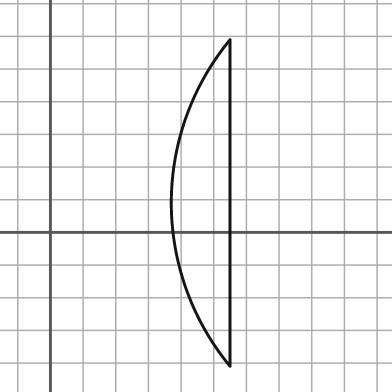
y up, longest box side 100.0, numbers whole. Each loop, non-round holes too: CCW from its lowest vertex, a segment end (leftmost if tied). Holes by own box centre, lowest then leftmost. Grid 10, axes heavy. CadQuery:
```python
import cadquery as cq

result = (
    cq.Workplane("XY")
    .moveTo(55.0, -41.0)
    .lineTo(55.0, 59.0)
    .threePointArc((37.0, 9.0), (55.0, -41.0))
    .close()
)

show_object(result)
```